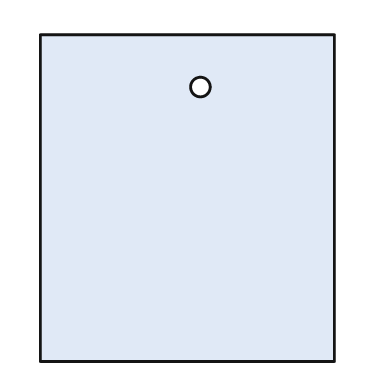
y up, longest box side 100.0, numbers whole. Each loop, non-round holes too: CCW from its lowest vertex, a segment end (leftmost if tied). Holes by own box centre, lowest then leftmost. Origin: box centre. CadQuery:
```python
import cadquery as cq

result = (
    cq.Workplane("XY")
    .moveTo(-45.0, -50.0)
    .lineTo(45.0, -50.0)
    .lineTo(45.0, 50.0)
    .lineTo(-45.0, 50.0)
    .close()
    .moveTo(4.0, 34.0)
    .circle(3.0)
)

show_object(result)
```